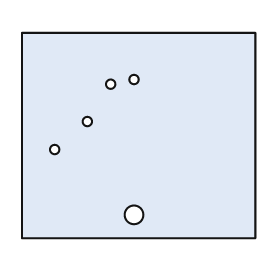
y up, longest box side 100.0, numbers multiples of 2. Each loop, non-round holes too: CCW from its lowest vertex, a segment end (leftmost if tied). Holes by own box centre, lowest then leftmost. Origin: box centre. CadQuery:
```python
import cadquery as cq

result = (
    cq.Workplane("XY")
    .moveTo(-50.0, -44.0)
    .lineTo(50.0, -44.0)
    .lineTo(50.0, 44.0)
    .lineTo(-50.0, 44.0)
    .close()
    .moveTo(-2.0, -34.0)
    .circle(4.0)
    .moveTo(-36.0, -6.0)
    .circle(2.0)
    .moveTo(-22.0, 6.0)
    .circle(2.0)
    .moveTo(-12.0, 22.0)
    .circle(2.0)
    .moveTo(-2.0, 24.0)
    .circle(2.0)
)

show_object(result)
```